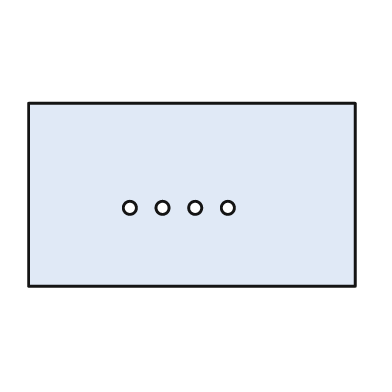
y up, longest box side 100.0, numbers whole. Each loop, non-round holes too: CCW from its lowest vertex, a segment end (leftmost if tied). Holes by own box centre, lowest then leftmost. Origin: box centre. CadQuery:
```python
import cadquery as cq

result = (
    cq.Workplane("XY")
    .moveTo(-50.0, -28.0)
    .lineTo(50.0, -28.0)
    .lineTo(50.0, 28.0)
    .lineTo(-50.0, 28.0)
    .close()
    .moveTo(-19.0, -4.0)
    .circle(2.0)
    .moveTo(-9.0, -4.0)
    .circle(2.0)
    .moveTo(1.0, -4.0)
    .circle(2.0)
    .moveTo(11.0, -4.0)
    .circle(2.0)
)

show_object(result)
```